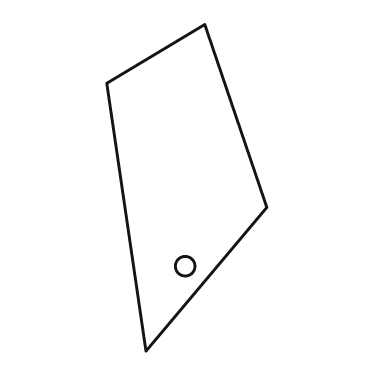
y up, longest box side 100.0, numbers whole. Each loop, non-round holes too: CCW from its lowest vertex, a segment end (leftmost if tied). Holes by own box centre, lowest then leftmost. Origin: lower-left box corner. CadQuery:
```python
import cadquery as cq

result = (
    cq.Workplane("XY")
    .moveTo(12.0, 0.0)
    .lineTo(49.0, 44.0)
    .lineTo(30.0, 100.0)
    .lineTo(0.0, 82.0)
    .close()
    .moveTo(24.0, 26.0)
    .circle(3.0)
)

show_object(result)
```